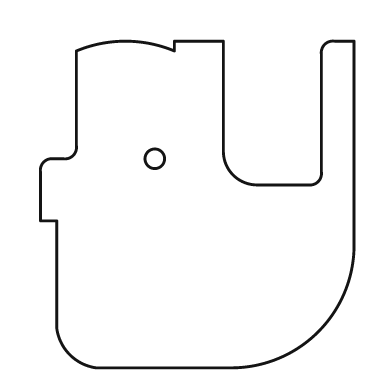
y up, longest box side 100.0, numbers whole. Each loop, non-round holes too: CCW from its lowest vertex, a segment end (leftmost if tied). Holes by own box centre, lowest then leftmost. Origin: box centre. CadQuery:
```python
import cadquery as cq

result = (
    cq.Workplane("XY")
    .moveTo(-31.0, -50.0)
    .lineTo(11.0, -50.0)
    .threePointArc((37.0, -39.0), (48.0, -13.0))
    .lineTo(48.0, 50.0)
    .lineTo(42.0, 50.0)
    .threePointArc((39.0, 49.0), (38.0, 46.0))
    .lineTo(38.0, 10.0)
    .threePointArc((37.0, 7.0), (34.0, 6.0))
    .lineTo(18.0, 6.0)
    .threePointArc((11.0, 9.0), (8.0, 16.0))
    .lineTo(8.0, 50.0)
    .lineTo(-7.0, 50.0)
    .lineTo(-7.0, 47.0)
    .threePointArc((-22.0, 50.0), (-37.0, 47.0))
    .lineTo(-37.0, 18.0)
    .threePointArc((-38.0, 15.0), (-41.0, 14.0))
    .lineTo(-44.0, 14.0)
    .threePointArc((-47.0, 13.0), (-48.0, 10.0))
    .lineTo(-48.0, -5.0)
    .lineTo(-43.0, -5.0)
    .lineTo(-43.0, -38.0)
    .threePointArc((-39.0, -46.0), (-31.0, -50.0))
    .close()
    .moveTo(-13.0, 14.0)
    .circle(3.0)
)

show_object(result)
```